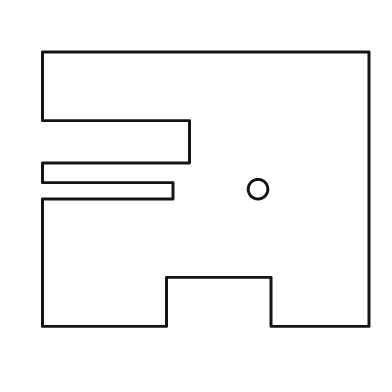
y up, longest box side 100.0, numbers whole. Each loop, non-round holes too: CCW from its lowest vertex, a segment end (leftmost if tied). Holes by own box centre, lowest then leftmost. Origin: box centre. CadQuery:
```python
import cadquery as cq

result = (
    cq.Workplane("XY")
    .moveTo(-50.0, -42.0)
    .lineTo(-12.0, -42.0)
    .lineTo(-12.0, -27.0)
    .lineTo(20.0, -27.0)
    .lineTo(20.0, -42.0)
    .lineTo(50.0, -42.0)
    .lineTo(50.0, 42.0)
    .lineTo(-50.0, 42.0)
    .lineTo(-50.0, 21.0)
    .lineTo(-5.0, 21.0)
    .lineTo(-5.0, 8.0)
    .lineTo(-50.0, 8.0)
    .lineTo(-50.0, 2.0)
    .lineTo(-10.0, 2.0)
    .lineTo(-10.0, -3.0)
    .lineTo(-50.0, -3.0)
    .close()
    .moveTo(16.0, 0.0)
    .circle(3.0)
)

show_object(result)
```